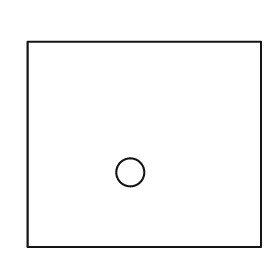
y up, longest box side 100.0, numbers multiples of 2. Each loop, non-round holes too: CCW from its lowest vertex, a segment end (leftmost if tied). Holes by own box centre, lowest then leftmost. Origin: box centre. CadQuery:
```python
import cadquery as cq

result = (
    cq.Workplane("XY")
    .moveTo(-50.0, -44.0)
    .lineTo(50.0, -44.0)
    .lineTo(50.0, 44.0)
    .lineTo(-50.0, 44.0)
    .close()
    .moveTo(-6.0, -12.0)
    .circle(6.0)
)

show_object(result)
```